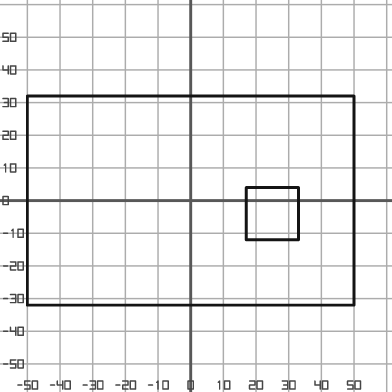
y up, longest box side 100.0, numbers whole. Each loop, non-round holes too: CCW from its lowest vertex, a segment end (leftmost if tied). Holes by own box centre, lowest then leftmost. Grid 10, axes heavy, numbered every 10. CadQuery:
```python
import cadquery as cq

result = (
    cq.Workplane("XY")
    .moveTo(-50.0, -32.0)
    .lineTo(50.0, -32.0)
    .lineTo(50.0, 32.0)
    .lineTo(-50.0, 32.0)
    .close()
    .moveTo(17.0, -12.0)
    .lineTo(33.0, -12.0)
    .lineTo(33.0, 4.0)
    .lineTo(17.0, 4.0)
    .close()
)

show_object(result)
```